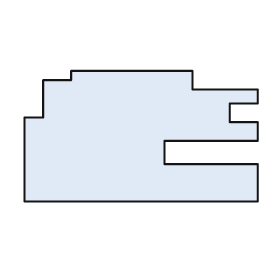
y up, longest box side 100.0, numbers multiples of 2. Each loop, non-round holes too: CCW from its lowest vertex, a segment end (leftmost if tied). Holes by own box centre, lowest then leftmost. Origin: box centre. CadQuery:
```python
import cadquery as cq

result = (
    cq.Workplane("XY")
    .moveTo(-50.0, -28.0)
    .lineTo(50.0, -28.0)
    .lineTo(50.0, -12.0)
    .lineTo(10.0, -12.0)
    .lineTo(10.0, -2.0)
    .lineTo(50.0, -2.0)
    .lineTo(50.0, 6.0)
    .lineTo(38.0, 6.0)
    .lineTo(38.0, 14.0)
    .lineTo(50.0, 14.0)
    .lineTo(50.0, 20.0)
    .lineTo(22.0, 20.0)
    .lineTo(22.0, 28.0)
    .lineTo(-30.0, 28.0)
    .lineTo(-30.0, 24.0)
    .lineTo(-42.0, 24.0)
    .lineTo(-42.0, 8.0)
    .lineTo(-50.0, 8.0)
    .close()
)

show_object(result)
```